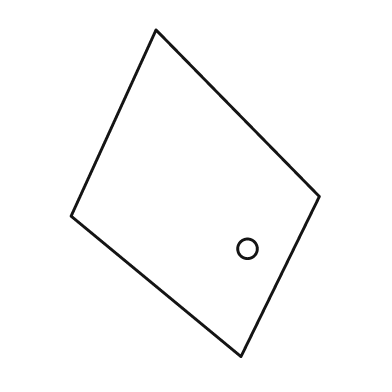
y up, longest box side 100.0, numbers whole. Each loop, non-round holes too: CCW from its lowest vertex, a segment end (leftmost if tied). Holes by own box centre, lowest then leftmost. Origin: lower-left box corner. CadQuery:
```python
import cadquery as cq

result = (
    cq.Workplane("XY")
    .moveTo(52.0, 0.0)
    .lineTo(76.0, 49.0)
    .lineTo(26.0, 100.0)
    .lineTo(0.0, 43.0)
    .close()
    .moveTo(54.0, 33.0)
    .circle(3.0)
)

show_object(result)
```